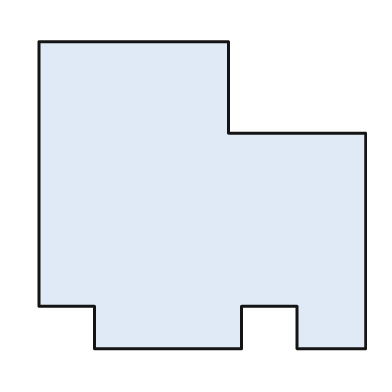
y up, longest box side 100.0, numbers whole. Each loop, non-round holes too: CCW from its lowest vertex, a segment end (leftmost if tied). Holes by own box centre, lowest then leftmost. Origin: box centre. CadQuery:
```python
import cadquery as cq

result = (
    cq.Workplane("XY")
    .moveTo(-33.0, -47.0)
    .lineTo(12.0, -47.0)
    .lineTo(12.0, -34.0)
    .lineTo(29.0, -34.0)
    .lineTo(29.0, -47.0)
    .lineTo(50.0, -47.0)
    .lineTo(50.0, 19.0)
    .lineTo(8.0, 19.0)
    .lineTo(8.0, 47.0)
    .lineTo(-50.0, 47.0)
    .lineTo(-50.0, -34.0)
    .lineTo(-33.0, -34.0)
    .close()
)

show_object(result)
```